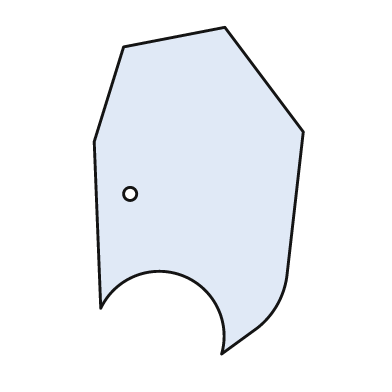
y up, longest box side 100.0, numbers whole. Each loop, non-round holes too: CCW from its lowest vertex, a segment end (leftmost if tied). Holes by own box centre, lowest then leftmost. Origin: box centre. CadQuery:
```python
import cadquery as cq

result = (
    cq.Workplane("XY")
    .moveTo(7.0, -50.0)
    .lineTo(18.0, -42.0)
    .threePointArc((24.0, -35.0), (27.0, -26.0))
    .lineTo(32.0, 18.0)
    .lineTo(8.0, 50.0)
    .lineTo(-23.0, 44.0)
    .lineTo(-32.0, 15.0)
    .lineTo(-30.0, -36.0)
    .threePointArc((-5.0, -26.0), (7.0, -50.0))
    .close()
    .moveTo(-21.0, -1.0)
    .circle(2.0)
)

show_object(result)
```